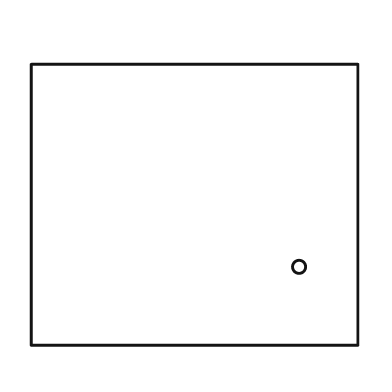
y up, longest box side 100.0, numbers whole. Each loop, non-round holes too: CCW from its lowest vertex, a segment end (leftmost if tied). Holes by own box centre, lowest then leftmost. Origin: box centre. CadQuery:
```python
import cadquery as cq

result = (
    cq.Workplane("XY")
    .moveTo(-50.0, -43.0)
    .lineTo(50.0, -43.0)
    .lineTo(50.0, 43.0)
    .lineTo(-50.0, 43.0)
    .close()
    .moveTo(32.0, -19.0)
    .circle(2.0)
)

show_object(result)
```